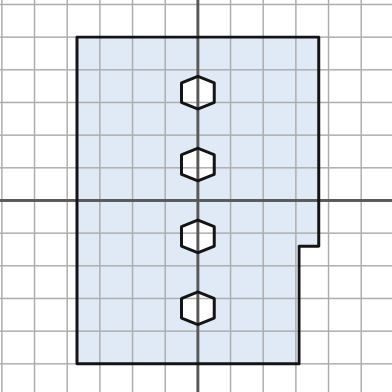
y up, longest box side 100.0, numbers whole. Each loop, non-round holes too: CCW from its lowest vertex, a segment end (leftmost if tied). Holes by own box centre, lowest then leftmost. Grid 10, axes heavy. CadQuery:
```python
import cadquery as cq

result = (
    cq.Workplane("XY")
    .moveTo(-37.0, -50.0)
    .lineTo(31.0, -50.0)
    .lineTo(31.0, -14.0)
    .lineTo(37.0, -14.0)
    .lineTo(37.0, 50.0)
    .lineTo(-37.0, 50.0)
    .close()
    .moveTo(0.0, -38.0)
    .lineTo(5.0, -36.0)
    .lineTo(5.0, -30.0)
    .lineTo(0.0, -28.0)
    .lineTo(-5.0, -30.0)
    .lineTo(-5.0, -36.0)
    .close()
    .moveTo(0.0, -16.0)
    .lineTo(5.0, -14.0)
    .lineTo(5.0, -8.0)
    .lineTo(0.0, -6.0)
    .lineTo(-5.0, -8.0)
    .lineTo(-5.0, -14.0)
    .close()
    .moveTo(0.0, 6.0)
    .lineTo(5.0, 8.0)
    .lineTo(5.0, 14.0)
    .lineTo(0.0, 16.0)
    .lineTo(-5.0, 14.0)
    .lineTo(-5.0, 8.0)
    .close()
    .moveTo(0.0, 28.0)
    .lineTo(5.0, 30.0)
    .lineTo(5.0, 36.0)
    .lineTo(0.0, 38.0)
    .lineTo(-5.0, 36.0)
    .lineTo(-5.0, 30.0)
    .close()
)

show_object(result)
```